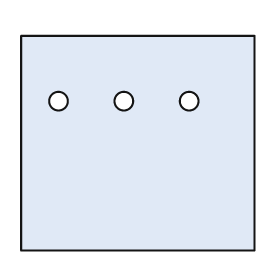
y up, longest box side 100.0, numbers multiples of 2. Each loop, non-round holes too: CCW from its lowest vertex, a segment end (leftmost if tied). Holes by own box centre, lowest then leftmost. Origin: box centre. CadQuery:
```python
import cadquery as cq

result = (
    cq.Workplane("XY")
    .moveTo(-50.0, -46.0)
    .lineTo(50.0, -46.0)
    .lineTo(50.0, 46.0)
    .lineTo(-50.0, 46.0)
    .close()
    .moveTo(-34.0, 18.0)
    .circle(4.0)
    .moveTo(-6.0, 18.0)
    .circle(4.0)
    .moveTo(22.0, 18.0)
    .circle(4.0)
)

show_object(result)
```